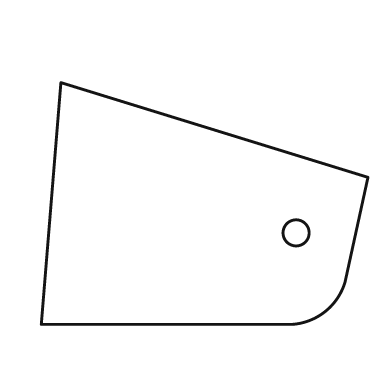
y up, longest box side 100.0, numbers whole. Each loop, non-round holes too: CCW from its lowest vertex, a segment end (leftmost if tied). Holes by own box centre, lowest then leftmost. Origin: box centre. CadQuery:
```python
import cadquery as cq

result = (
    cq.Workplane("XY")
    .moveTo(-50.0, -37.0)
    .lineTo(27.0, -37.0)
    .threePointArc((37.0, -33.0), (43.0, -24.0))
    .lineTo(50.0, 8.0)
    .lineTo(-44.0, 37.0)
    .close()
    .moveTo(28.0, -9.0)
    .circle(4.0)
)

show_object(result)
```